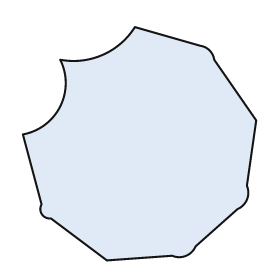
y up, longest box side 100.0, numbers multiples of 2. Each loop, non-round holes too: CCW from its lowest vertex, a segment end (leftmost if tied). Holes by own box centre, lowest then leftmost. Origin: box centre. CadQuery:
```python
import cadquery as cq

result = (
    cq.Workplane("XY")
    .moveTo(-14.0, -50.0)
    .lineTo(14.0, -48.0)
    .threePointArc((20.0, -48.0), (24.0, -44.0))
    .lineTo(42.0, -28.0)
    .threePointArc((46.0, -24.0), (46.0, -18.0))
    .lineTo(50.0, 10.0)
    .lineTo(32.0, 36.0)
    .threePointArc((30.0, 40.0), (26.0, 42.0))
    .lineTo(-2.0, 50.0)
    .threePointArc((-16.0, 38.0), (-34.0, 36.0))
    .threePointArc((-34.0, 16.0), (-50.0, 4.0))
    .lineTo(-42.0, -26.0)
    .threePointArc((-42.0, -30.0), (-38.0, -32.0))
    .close()
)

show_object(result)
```